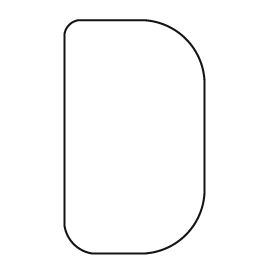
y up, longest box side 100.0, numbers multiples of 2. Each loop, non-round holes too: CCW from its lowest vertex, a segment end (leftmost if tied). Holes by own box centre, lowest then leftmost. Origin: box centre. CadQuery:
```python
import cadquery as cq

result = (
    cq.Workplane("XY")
    .moveTo(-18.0, -50.0)
    .lineTo(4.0, -50.0)
    .threePointArc((22.0, -42.0), (30.0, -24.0))
    .lineTo(30.0, 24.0)
    .threePointArc((22.0, 42.0), (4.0, 50.0))
    .lineTo(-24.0, 50.0)
    .threePointArc((-28.0, 48.0), (-30.0, 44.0))
    .lineTo(-30.0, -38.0)
    .threePointArc((-26.0, -46.0), (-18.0, -50.0))
    .close()
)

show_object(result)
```